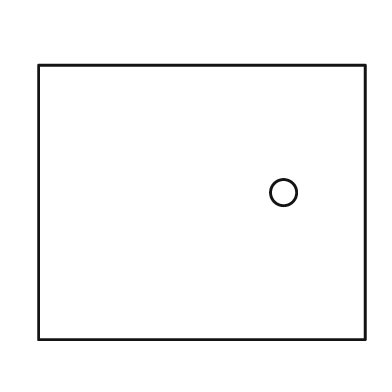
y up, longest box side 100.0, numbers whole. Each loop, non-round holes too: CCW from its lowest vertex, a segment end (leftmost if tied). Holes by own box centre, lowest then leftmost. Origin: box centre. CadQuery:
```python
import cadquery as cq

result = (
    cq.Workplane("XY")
    .moveTo(-50.0, -42.0)
    .lineTo(50.0, -42.0)
    .lineTo(50.0, 42.0)
    .lineTo(-50.0, 42.0)
    .close()
    .moveTo(25.0, 3.0)
    .circle(4.0)
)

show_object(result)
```